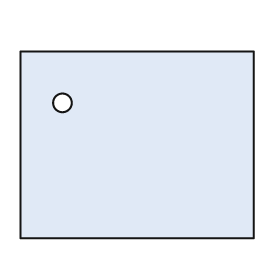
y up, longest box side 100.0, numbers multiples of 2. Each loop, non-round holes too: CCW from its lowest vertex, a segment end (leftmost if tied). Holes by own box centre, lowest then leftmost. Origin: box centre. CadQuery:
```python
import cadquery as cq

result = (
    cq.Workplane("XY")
    .moveTo(-50.0, -40.0)
    .lineTo(50.0, -40.0)
    .lineTo(50.0, 40.0)
    .lineTo(-50.0, 40.0)
    .close()
    .moveTo(-32.0, 18.0)
    .circle(4.0)
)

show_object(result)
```